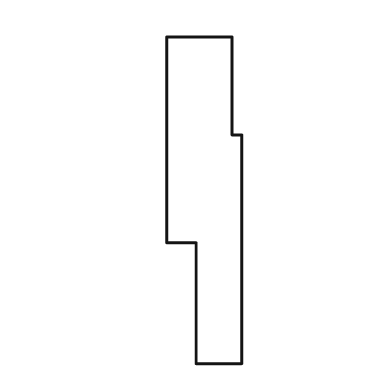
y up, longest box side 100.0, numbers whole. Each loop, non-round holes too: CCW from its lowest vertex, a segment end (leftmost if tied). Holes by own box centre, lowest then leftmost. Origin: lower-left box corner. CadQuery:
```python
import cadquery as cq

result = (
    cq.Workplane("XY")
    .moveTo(9.0, 0.0)
    .lineTo(23.0, 0.0)
    .lineTo(23.0, 70.0)
    .lineTo(20.0, 70.0)
    .lineTo(20.0, 100.0)
    .lineTo(0.0, 100.0)
    .lineTo(0.0, 37.0)
    .lineTo(9.0, 37.0)
    .close()
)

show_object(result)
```